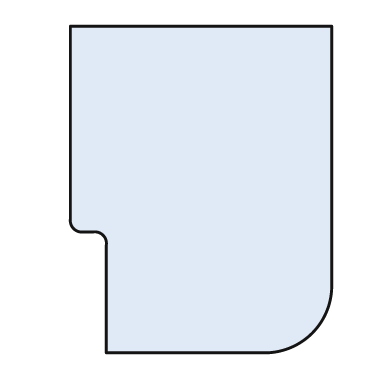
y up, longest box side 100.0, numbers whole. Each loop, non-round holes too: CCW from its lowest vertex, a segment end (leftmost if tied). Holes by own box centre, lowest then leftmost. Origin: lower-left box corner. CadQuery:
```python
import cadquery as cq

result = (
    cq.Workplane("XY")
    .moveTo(11.0, 0.0)
    .lineTo(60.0, 0.0)
    .threePointArc((74.0, 6.0), (80.0, 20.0))
    .lineTo(80.0, 100.0)
    .lineTo(0.0, 100.0)
    .lineTo(0.0, 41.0)
    .threePointArc((1.0, 38.0), (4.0, 37.0))
    .lineTo(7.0, 37.0)
    .threePointArc((10.0, 36.0), (11.0, 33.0))
    .close()
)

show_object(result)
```